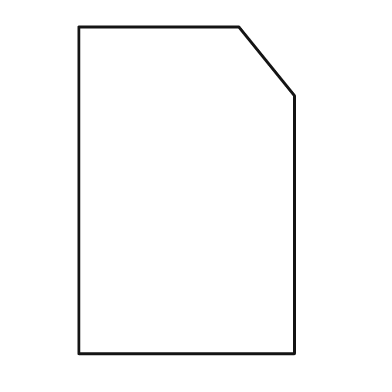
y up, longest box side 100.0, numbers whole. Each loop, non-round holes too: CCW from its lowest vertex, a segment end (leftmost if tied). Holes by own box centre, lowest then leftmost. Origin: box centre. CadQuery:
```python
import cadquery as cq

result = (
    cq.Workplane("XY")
    .moveTo(-33.0, -50.0)
    .lineTo(33.0, -50.0)
    .lineTo(33.0, 29.0)
    .lineTo(16.0, 50.0)
    .lineTo(-33.0, 50.0)
    .close()
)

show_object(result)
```